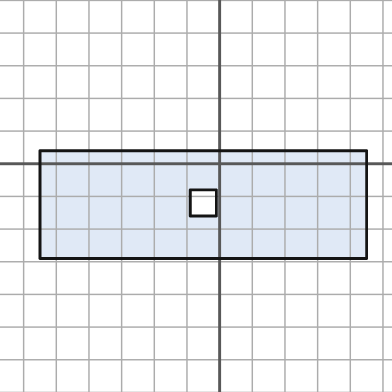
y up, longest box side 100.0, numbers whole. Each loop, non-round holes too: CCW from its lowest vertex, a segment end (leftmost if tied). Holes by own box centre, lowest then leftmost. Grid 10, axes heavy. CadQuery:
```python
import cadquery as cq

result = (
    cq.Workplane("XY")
    .moveTo(-55.0, -29.0)
    .lineTo(45.0, -29.0)
    .lineTo(45.0, 4.0)
    .lineTo(-55.0, 4.0)
    .close()
    .moveTo(-9.0, -16.0)
    .lineTo(-1.0, -16.0)
    .lineTo(-1.0, -8.0)
    .lineTo(-9.0, -8.0)
    .close()
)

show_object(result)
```